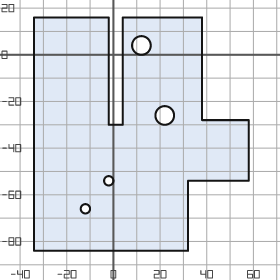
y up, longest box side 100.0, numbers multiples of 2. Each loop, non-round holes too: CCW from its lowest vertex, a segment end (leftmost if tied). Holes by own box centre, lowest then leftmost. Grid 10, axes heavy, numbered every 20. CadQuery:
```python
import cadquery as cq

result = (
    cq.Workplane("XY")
    .moveTo(-34.0, -84.0)
    .lineTo(32.0, -84.0)
    .lineTo(32.0, -54.0)
    .lineTo(58.0, -54.0)
    .lineTo(58.0, -28.0)
    .lineTo(38.0, -28.0)
    .lineTo(38.0, 16.0)
    .lineTo(4.0, 16.0)
    .lineTo(4.0, -30.0)
    .lineTo(-2.0, -30.0)
    .lineTo(-2.0, 16.0)
    .lineTo(-34.0, 16.0)
    .close()
    .moveTo(-12.0, -66.0)
    .circle(2.0)
    .moveTo(-2.0, -54.0)
    .circle(2.0)
    .moveTo(22.0, -26.0)
    .circle(4.0)
    .moveTo(12.0, 4.0)
    .circle(4.0)
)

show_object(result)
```